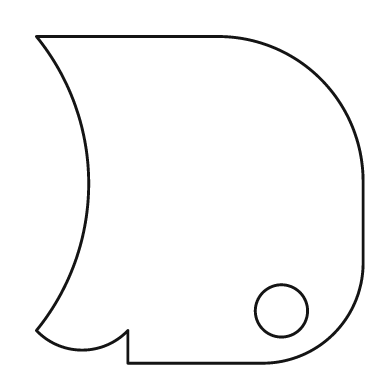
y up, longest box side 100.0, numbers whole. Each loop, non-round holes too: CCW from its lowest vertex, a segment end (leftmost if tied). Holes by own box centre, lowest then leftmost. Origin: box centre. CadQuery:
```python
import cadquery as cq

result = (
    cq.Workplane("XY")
    .moveTo(-22.0, -50.0)
    .lineTo(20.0, -50.0)
    .threePointArc((41.0, -41.0), (50.0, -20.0))
    .lineTo(50.0, 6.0)
    .threePointArc((37.0, 37.0), (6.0, 50.0))
    .lineTo(-50.0, 50.0)
    .threePointArc((-34.0, 5.0), (-50.0, -40.0))
    .threePointArc((-36.0, -46.0), (-22.0, -40.0))
    .close()
    .moveTo(25.0, -34.0)
    .circle(8.0)
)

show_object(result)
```